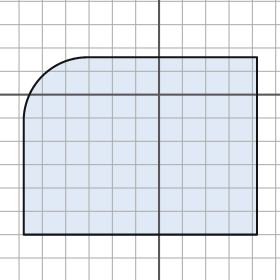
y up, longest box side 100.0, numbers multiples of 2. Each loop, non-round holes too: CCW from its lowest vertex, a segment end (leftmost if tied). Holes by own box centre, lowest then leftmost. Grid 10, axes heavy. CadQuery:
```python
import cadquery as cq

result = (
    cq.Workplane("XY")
    .moveTo(-58.0, -60.0)
    .lineTo(42.0, -60.0)
    .lineTo(42.0, 16.0)
    .lineTo(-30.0, 16.0)
    .threePointArc((-50.0, 8.0), (-58.0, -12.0))
    .close()
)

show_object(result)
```